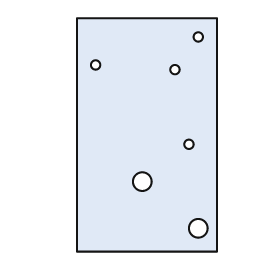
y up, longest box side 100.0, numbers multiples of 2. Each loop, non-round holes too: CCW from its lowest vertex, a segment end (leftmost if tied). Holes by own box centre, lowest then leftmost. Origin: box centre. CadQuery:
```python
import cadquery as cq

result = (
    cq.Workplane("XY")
    .moveTo(-30.0, -50.0)
    .lineTo(30.0, -50.0)
    .lineTo(30.0, 50.0)
    .lineTo(-30.0, 50.0)
    .close()
    .moveTo(22.0, -40.0)
    .circle(4.0)
    .moveTo(-2.0, -20.0)
    .circle(4.0)
    .moveTo(18.0, -4.0)
    .circle(2.0)
    .moveTo(12.0, 28.0)
    .circle(2.0)
    .moveTo(-22.0, 30.0)
    .circle(2.0)
    .moveTo(22.0, 42.0)
    .circle(2.0)
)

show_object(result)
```